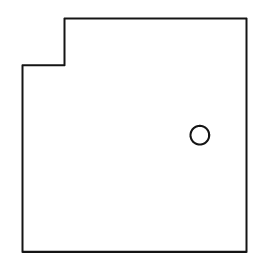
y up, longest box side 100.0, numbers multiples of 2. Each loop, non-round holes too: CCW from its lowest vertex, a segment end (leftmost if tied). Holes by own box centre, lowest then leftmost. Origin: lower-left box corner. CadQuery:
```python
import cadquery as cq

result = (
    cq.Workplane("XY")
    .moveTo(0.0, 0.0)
    .lineTo(96.0, 0.0)
    .lineTo(96.0, 100.0)
    .lineTo(18.0, 100.0)
    .lineTo(18.0, 80.0)
    .lineTo(0.0, 80.0)
    .close()
    .moveTo(76.0, 50.0)
    .circle(4.0)
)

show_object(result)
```